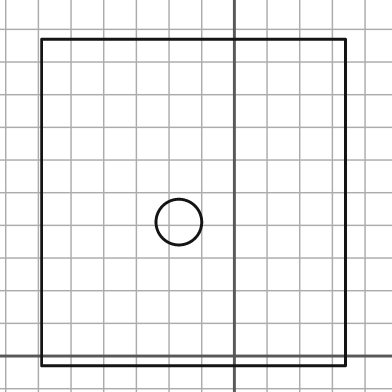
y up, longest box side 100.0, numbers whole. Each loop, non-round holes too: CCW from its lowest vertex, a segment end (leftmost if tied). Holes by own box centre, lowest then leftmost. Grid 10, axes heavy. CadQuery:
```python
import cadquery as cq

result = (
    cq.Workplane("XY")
    .moveTo(-59.0, -3.0)
    .lineTo(34.0, -3.0)
    .lineTo(34.0, 97.0)
    .lineTo(-59.0, 97.0)
    .close()
    .moveTo(-17.0, 41.0)
    .circle(7.0)
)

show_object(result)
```